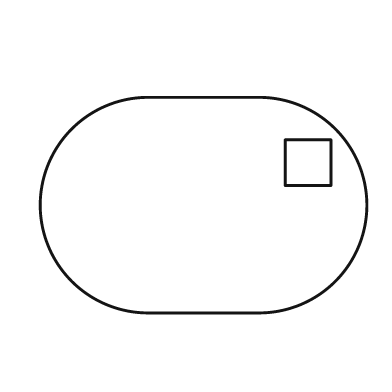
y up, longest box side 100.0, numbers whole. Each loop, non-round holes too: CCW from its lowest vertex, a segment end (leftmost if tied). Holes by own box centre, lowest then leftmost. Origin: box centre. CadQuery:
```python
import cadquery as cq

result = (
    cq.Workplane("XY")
    .moveTo(-17.0, -33.0)
    .lineTo(17.0, -33.0)
    .threePointArc((50.0, 0.0), (17.0, 33.0))
    .lineTo(-17.0, 33.0)
    .threePointArc((-50.0, 0.0), (-17.0, -33.0))
    .close()
    .moveTo(25.0, 6.0)
    .lineTo(39.0, 6.0)
    .lineTo(39.0, 20.0)
    .lineTo(25.0, 20.0)
    .close()
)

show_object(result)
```